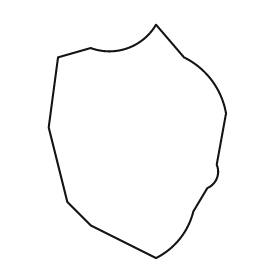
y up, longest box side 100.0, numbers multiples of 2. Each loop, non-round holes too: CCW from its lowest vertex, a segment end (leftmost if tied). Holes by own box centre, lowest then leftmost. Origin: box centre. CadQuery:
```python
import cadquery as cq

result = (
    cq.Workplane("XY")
    .moveTo(8.0, -50.0)
    .threePointArc((18.0, -42.0), (24.0, -30.0))
    .lineTo(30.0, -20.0)
    .threePointArc((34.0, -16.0), (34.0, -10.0))
    .lineTo(38.0, 12.0)
    .threePointArc((32.0, 26.0), (20.0, 36.0))
    .lineTo(8.0, 50.0)
    .threePointArc((-4.0, 40.0), (-20.0, 40.0))
    .lineTo(-34.0, 36.0)
    .lineTo(-38.0, 6.0)
    .lineTo(-30.0, -26.0)
    .lineTo(-20.0, -36.0)
    .close()
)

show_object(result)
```